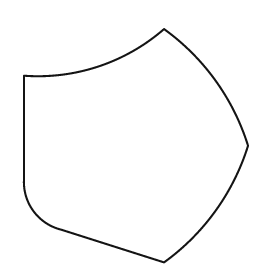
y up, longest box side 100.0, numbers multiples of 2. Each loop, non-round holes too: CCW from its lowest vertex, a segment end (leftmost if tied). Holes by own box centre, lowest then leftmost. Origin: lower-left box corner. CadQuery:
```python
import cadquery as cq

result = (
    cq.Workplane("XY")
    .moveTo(60.0, 0.0)
    .threePointArc((82.0, 22.0), (96.0, 50.0))
    .threePointArc((82.0, 78.0), (60.0, 100.0))
    .threePointArc((32.0, 84.0), (0.0, 80.0))
    .lineTo(0.0, 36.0)
    .threePointArc((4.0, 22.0), (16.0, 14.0))
    .close()
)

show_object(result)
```